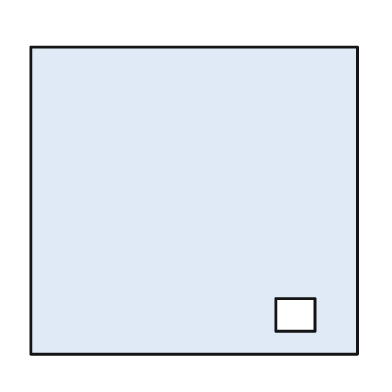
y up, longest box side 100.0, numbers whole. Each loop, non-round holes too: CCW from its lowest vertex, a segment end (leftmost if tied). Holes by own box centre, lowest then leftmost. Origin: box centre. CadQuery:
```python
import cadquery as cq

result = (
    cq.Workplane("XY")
    .moveTo(-50.0, -47.0)
    .lineTo(50.0, -47.0)
    .lineTo(50.0, 47.0)
    .lineTo(-50.0, 47.0)
    .close()
    .moveTo(25.0, -40.0)
    .lineTo(37.0, -40.0)
    .lineTo(37.0, -30.0)
    .lineTo(25.0, -30.0)
    .close()
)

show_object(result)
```